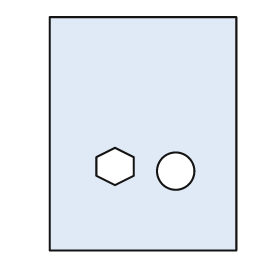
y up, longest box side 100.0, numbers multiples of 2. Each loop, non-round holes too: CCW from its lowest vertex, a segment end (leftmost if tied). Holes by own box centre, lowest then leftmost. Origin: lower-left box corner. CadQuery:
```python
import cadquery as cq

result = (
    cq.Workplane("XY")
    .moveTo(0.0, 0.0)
    .lineTo(80.0, 0.0)
    .lineTo(80.0, 100.0)
    .lineTo(0.0, 100.0)
    .close()
    .moveTo(54.0, 34.0)
    .circle(8.0)
    .moveTo(28.0, 28.0)
    .lineTo(36.0, 32.0)
    .lineTo(36.0, 40.0)
    .lineTo(28.0, 44.0)
    .lineTo(20.0, 40.0)
    .lineTo(20.0, 32.0)
    .close()
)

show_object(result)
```